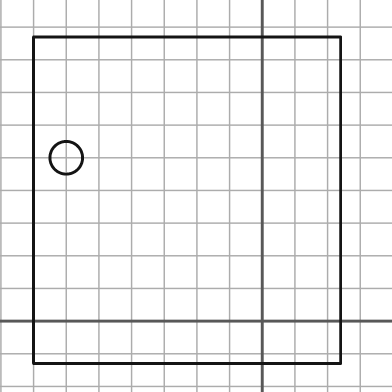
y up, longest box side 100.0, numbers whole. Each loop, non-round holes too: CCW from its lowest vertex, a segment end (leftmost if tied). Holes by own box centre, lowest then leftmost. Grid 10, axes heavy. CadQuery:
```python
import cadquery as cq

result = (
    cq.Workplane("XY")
    .moveTo(-70.0, -13.0)
    .lineTo(24.0, -13.0)
    .lineTo(24.0, 87.0)
    .lineTo(-70.0, 87.0)
    .close()
    .moveTo(-60.0, 50.0)
    .circle(5.0)
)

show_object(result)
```